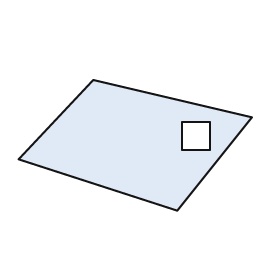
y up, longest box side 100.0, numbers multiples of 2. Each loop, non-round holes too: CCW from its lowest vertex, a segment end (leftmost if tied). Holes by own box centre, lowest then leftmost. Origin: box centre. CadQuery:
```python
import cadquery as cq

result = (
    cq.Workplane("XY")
    .moveTo(18.0, -28.0)
    .lineTo(50.0, 12.0)
    .lineTo(-18.0, 28.0)
    .lineTo(-50.0, -6.0)
    .close()
    .moveTo(20.0, -2.0)
    .lineTo(32.0, -2.0)
    .lineTo(32.0, 10.0)
    .lineTo(20.0, 10.0)
    .close()
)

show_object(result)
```